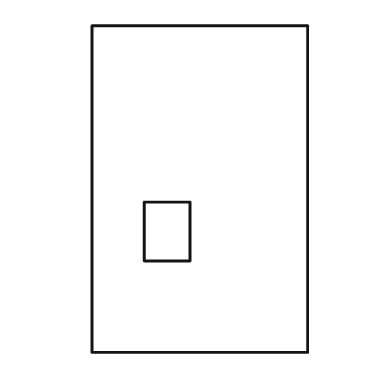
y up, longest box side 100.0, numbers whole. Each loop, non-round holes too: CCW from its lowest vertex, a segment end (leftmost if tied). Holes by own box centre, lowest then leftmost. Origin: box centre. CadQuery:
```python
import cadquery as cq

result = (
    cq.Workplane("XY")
    .moveTo(-33.0, -50.0)
    .lineTo(33.0, -50.0)
    .lineTo(33.0, 50.0)
    .lineTo(-33.0, 50.0)
    .close()
    .moveTo(-17.0, -22.0)
    .lineTo(-3.0, -22.0)
    .lineTo(-3.0, -4.0)
    .lineTo(-17.0, -4.0)
    .close()
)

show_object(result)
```